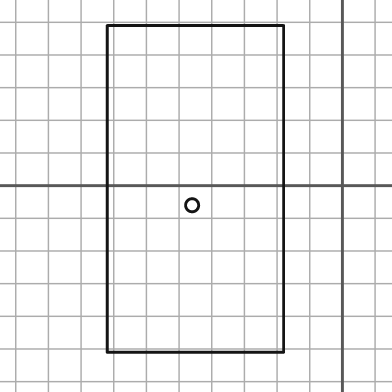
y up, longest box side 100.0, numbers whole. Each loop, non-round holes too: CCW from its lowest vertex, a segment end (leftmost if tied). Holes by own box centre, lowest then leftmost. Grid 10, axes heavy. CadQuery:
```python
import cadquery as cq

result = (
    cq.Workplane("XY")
    .moveTo(-72.0, -51.0)
    .lineTo(-18.0, -51.0)
    .lineTo(-18.0, 49.0)
    .lineTo(-72.0, 49.0)
    .close()
    .moveTo(-46.0, -6.0)
    .circle(2.0)
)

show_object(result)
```